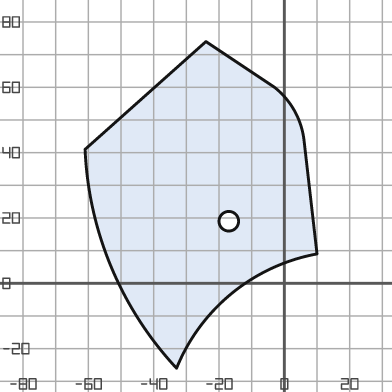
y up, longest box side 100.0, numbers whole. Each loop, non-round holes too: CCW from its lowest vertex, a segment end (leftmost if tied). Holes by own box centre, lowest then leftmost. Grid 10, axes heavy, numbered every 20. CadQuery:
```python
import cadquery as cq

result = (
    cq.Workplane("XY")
    .moveTo(-33.0, -26.0)
    .threePointArc((-16.0, -3.0), (10.0, 9.0))
    .lineTo(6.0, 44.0)
    .threePointArc((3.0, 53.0), (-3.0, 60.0))
    .lineTo(-24.0, 74.0)
    .lineTo(-61.0, 41.0)
    .threePointArc((-53.0, 5.0), (-33.0, -26.0))
    .close()
    .moveTo(-17.0, 19.0)
    .circle(3.0)
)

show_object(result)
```